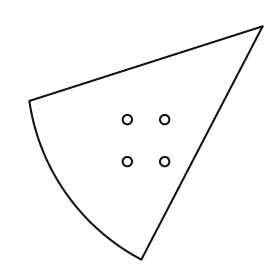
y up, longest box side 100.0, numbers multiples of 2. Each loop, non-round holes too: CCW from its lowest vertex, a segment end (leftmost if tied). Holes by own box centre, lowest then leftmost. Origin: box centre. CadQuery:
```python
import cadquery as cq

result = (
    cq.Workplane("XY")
    .moveTo(-2.0, -50.0)
    .lineTo(50.0, 50.0)
    .lineTo(-50.0, 18.0)
    .threePointArc((-34.0, -22.0), (-2.0, -50.0))
    .close()
    .moveTo(-8.0, -8.0)
    .circle(2.0)
    .moveTo(8.0, -8.0)
    .circle(2.0)
    .moveTo(-8.0, 10.0)
    .circle(2.0)
    .moveTo(8.0, 10.0)
    .circle(2.0)
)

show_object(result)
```